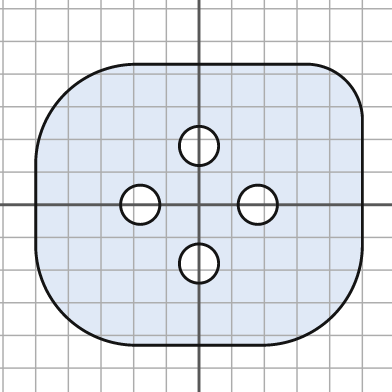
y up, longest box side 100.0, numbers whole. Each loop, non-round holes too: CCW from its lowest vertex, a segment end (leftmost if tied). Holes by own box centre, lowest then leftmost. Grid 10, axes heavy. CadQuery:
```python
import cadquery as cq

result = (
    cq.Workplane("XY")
    .moveTo(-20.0, -43.0)
    .lineTo(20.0, -43.0)
    .threePointArc((41.0, -34.0), (50.0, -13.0))
    .lineTo(50.0, 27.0)
    .threePointArc((45.0, 38.0), (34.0, 43.0))
    .lineTo(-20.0, 43.0)
    .threePointArc((-41.0, 34.0), (-50.0, 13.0))
    .lineTo(-50.0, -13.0)
    .threePointArc((-41.0, -34.0), (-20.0, -43.0))
    .close()
    .moveTo(0.0, -18.0)
    .circle(6.0)
    .moveTo(-18.0, 0.0)
    .circle(6.0)
    .moveTo(18.0, 0.0)
    .circle(6.0)
    .moveTo(0.0, 18.0)
    .circle(6.0)
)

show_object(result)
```